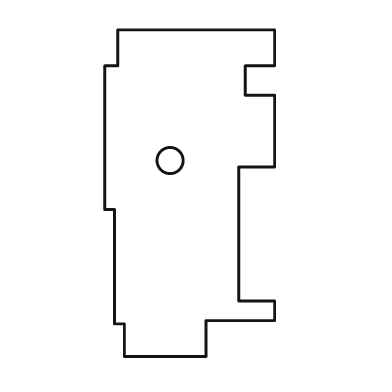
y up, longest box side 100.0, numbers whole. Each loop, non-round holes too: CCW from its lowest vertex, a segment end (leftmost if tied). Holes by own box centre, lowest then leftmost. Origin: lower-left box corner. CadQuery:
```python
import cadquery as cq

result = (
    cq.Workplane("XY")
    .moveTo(6.0, 0.0)
    .lineTo(31.0, 0.0)
    .lineTo(31.0, 11.0)
    .lineTo(52.0, 11.0)
    .lineTo(52.0, 17.0)
    .lineTo(41.0, 17.0)
    .lineTo(41.0, 58.0)
    .lineTo(52.0, 58.0)
    .lineTo(52.0, 80.0)
    .lineTo(43.0, 80.0)
    .lineTo(43.0, 89.0)
    .lineTo(52.0, 89.0)
    .lineTo(52.0, 100.0)
    .lineTo(4.0, 100.0)
    .lineTo(4.0, 89.0)
    .lineTo(0.0, 89.0)
    .lineTo(0.0, 45.0)
    .lineTo(3.0, 45.0)
    .lineTo(3.0, 10.0)
    .lineTo(6.0, 10.0)
    .close()
    .moveTo(20.0, 60.0)
    .circle(4.0)
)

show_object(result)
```